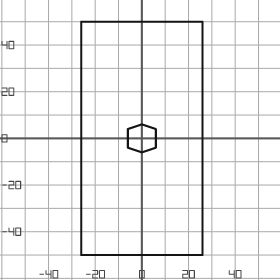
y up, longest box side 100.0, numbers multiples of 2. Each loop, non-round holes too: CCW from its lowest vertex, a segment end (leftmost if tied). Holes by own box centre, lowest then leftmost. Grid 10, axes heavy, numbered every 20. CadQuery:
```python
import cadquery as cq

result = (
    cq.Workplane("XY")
    .moveTo(-26.0, -50.0)
    .lineTo(26.0, -50.0)
    .lineTo(26.0, 50.0)
    .lineTo(-26.0, 50.0)
    .close()
    .moveTo(0.0, -6.0)
    .lineTo(6.0, -4.0)
    .lineTo(6.0, 4.0)
    .lineTo(0.0, 6.0)
    .lineTo(-6.0, 4.0)
    .lineTo(-6.0, -4.0)
    .close()
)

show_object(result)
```